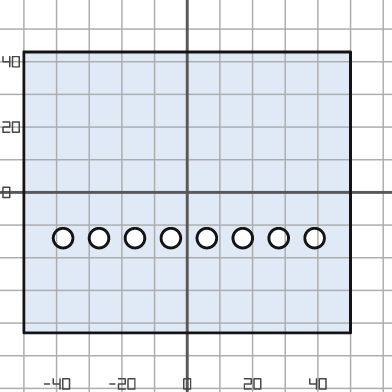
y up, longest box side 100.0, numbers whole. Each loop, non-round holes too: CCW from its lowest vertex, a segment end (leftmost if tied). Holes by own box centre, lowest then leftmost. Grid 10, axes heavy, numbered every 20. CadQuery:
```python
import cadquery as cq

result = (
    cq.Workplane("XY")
    .moveTo(-50.0, -43.0)
    .lineTo(50.0, -43.0)
    .lineTo(50.0, 43.0)
    .lineTo(-50.0, 43.0)
    .close()
    .moveTo(-38.0, -14.0)
    .circle(3.0)
    .moveTo(-27.0, -14.0)
    .circle(3.0)
    .moveTo(-16.0, -14.0)
    .circle(3.0)
    .moveTo(-5.0, -14.0)
    .circle(3.0)
    .moveTo(6.0, -14.0)
    .circle(3.0)
    .moveTo(17.0, -14.0)
    .circle(3.0)
    .moveTo(28.0, -14.0)
    .circle(3.0)
    .moveTo(39.0, -14.0)
    .circle(3.0)
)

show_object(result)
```